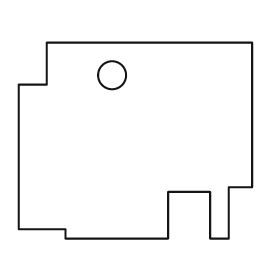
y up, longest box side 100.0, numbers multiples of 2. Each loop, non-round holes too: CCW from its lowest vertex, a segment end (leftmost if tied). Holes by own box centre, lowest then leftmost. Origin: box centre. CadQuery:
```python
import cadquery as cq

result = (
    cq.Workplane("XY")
    .moveTo(-30.0, -42.0)
    .lineTo(14.0, -42.0)
    .lineTo(14.0, -22.0)
    .lineTo(32.0, -22.0)
    .lineTo(32.0, -42.0)
    .lineTo(40.0, -42.0)
    .lineTo(40.0, -20.0)
    .lineTo(50.0, -20.0)
    .lineTo(50.0, 42.0)
    .lineTo(-38.0, 42.0)
    .lineTo(-38.0, 24.0)
    .lineTo(-50.0, 24.0)
    .lineTo(-50.0, -38.0)
    .lineTo(-30.0, -38.0)
    .close()
    .moveTo(-10.0, 28.0)
    .circle(6.0)
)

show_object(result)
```